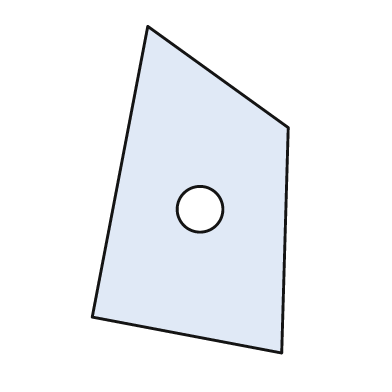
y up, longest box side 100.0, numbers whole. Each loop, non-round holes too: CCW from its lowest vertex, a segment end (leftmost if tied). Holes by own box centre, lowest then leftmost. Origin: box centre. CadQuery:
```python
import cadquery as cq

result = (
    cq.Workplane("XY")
    .moveTo(28.0, -50.0)
    .lineTo(30.0, 19.0)
    .lineTo(-13.0, 50.0)
    .lineTo(-30.0, -39.0)
    .close()
    .moveTo(3.0, -6.0)
    .circle(7.0)
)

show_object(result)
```